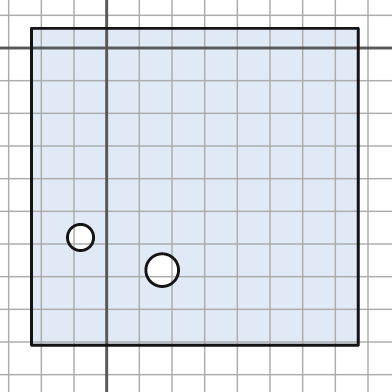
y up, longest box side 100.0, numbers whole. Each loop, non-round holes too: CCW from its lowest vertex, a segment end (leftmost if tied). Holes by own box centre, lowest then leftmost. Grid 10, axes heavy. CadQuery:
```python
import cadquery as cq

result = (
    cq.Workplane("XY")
    .moveTo(-23.0, -91.0)
    .lineTo(77.0, -91.0)
    .lineTo(77.0, 6.0)
    .lineTo(-23.0, 6.0)
    .close()
    .moveTo(17.0, -68.0)
    .circle(5.0)
    .moveTo(-8.0, -58.0)
    .circle(4.0)
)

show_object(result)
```